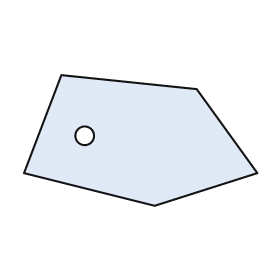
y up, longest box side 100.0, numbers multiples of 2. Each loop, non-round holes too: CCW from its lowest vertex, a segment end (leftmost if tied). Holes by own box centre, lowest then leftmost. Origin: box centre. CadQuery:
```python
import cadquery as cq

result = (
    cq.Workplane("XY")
    .moveTo(6.0, -28.0)
    .lineTo(50.0, -14.0)
    .lineTo(24.0, 22.0)
    .lineTo(-34.0, 28.0)
    .lineTo(-50.0, -14.0)
    .close()
    .moveTo(-24.0, 2.0)
    .circle(4.0)
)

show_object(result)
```